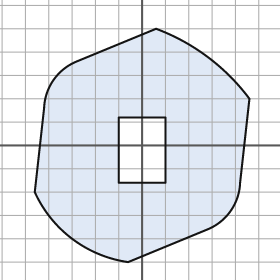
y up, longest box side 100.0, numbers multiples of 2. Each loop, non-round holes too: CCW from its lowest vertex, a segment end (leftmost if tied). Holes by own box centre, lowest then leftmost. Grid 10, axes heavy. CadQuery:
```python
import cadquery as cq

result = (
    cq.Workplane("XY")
    .moveTo(-6.0, -50.0)
    .lineTo(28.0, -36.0)
    .threePointArc((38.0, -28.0), (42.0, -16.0))
    .lineTo(46.0, 20.0)
    .threePointArc((28.0, 38.0), (6.0, 50.0))
    .lineTo(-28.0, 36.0)
    .threePointArc((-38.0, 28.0), (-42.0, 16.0))
    .lineTo(-46.0, -20.0)
    .threePointArc((-30.0, -40.0), (-6.0, -50.0))
    .close()
    .moveTo(-10.0, -16.0)
    .lineTo(10.0, -16.0)
    .lineTo(10.0, 12.0)
    .lineTo(-10.0, 12.0)
    .close()
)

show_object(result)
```